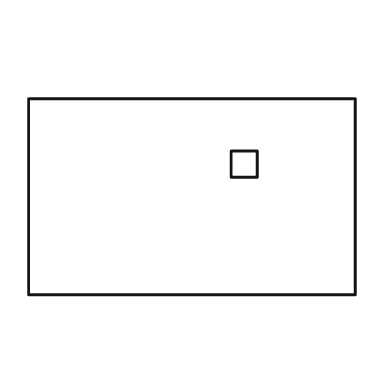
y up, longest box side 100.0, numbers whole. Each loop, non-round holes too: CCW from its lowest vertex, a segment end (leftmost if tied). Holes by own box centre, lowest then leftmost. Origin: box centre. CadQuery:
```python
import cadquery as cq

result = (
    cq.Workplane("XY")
    .moveTo(-50.0, -30.0)
    .lineTo(50.0, -30.0)
    .lineTo(50.0, 30.0)
    .lineTo(-50.0, 30.0)
    .close()
    .moveTo(12.0, 6.0)
    .lineTo(20.0, 6.0)
    .lineTo(20.0, 14.0)
    .lineTo(12.0, 14.0)
    .close()
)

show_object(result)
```